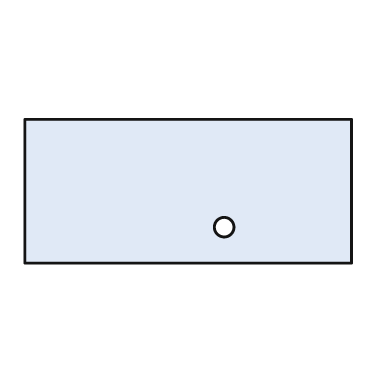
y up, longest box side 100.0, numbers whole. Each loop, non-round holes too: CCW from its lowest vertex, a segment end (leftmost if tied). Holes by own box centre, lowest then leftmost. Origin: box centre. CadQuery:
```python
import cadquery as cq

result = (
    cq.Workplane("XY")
    .moveTo(-50.0, -22.0)
    .lineTo(50.0, -22.0)
    .lineTo(50.0, 22.0)
    .lineTo(-50.0, 22.0)
    .close()
    .moveTo(11.0, -11.0)
    .circle(3.0)
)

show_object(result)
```